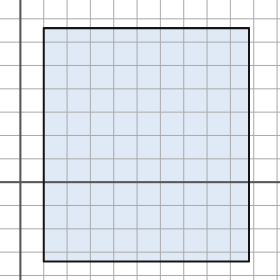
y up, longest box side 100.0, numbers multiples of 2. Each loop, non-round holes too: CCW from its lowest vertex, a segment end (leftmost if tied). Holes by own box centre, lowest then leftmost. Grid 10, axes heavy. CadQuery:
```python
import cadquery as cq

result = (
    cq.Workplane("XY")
    .moveTo(10.0, -34.0)
    .lineTo(98.0, -34.0)
    .lineTo(98.0, 66.0)
    .lineTo(10.0, 66.0)
    .close()
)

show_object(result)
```